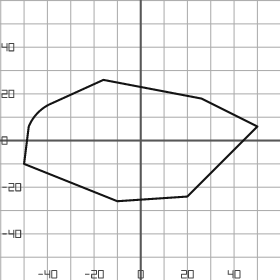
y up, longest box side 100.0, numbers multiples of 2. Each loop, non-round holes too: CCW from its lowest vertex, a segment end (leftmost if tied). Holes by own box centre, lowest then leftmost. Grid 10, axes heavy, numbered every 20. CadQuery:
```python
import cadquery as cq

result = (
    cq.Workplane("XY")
    .moveTo(-10.0, -26.0)
    .lineTo(20.0, -24.0)
    .lineTo(50.0, 6.0)
    .lineTo(26.0, 18.0)
    .lineTo(-16.0, 26.0)
    .lineTo(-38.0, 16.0)
    .threePointArc((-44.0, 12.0), (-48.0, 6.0))
    .lineTo(-50.0, -10.0)
    .close()
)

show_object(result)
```